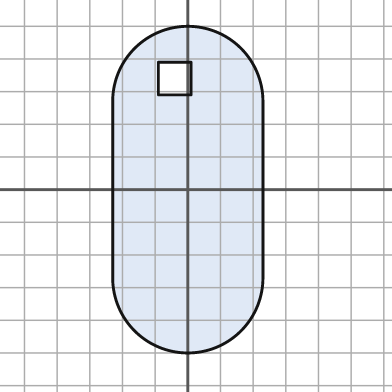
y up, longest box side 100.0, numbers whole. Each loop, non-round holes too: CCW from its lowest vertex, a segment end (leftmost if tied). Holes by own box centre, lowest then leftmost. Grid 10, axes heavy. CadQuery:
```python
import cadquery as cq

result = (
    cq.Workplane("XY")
    .moveTo(-23.0, -27.0)
    .threePointArc((0.0, -50.0), (23.0, -27.0))
    .lineTo(23.0, 27.0)
    .threePointArc((0.0, 50.0), (-23.0, 27.0))
    .close()
    .moveTo(-9.0, 29.0)
    .lineTo(1.0, 29.0)
    .lineTo(1.0, 39.0)
    .lineTo(-9.0, 39.0)
    .close()
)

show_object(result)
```